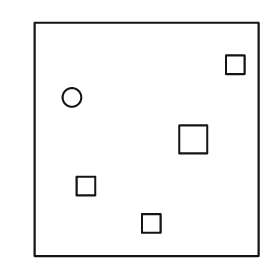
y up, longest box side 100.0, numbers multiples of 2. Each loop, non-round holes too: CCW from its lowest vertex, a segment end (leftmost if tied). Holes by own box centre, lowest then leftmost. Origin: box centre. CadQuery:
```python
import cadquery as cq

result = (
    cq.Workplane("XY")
    .moveTo(-48.0, -50.0)
    .lineTo(48.0, -50.0)
    .lineTo(48.0, 50.0)
    .lineTo(-48.0, 50.0)
    .close()
    .moveTo(-2.0, -40.0)
    .lineTo(6.0, -40.0)
    .lineTo(6.0, -32.0)
    .lineTo(-2.0, -32.0)
    .close()
    .moveTo(-30.0, -24.0)
    .lineTo(-22.0, -24.0)
    .lineTo(-22.0, -16.0)
    .lineTo(-30.0, -16.0)
    .close()
    .moveTo(14.0, -6.0)
    .lineTo(26.0, -6.0)
    .lineTo(26.0, 6.0)
    .lineTo(14.0, 6.0)
    .close()
    .moveTo(-32.0, 18.0)
    .circle(4.0)
    .moveTo(34.0, 28.0)
    .lineTo(42.0, 28.0)
    .lineTo(42.0, 36.0)
    .lineTo(34.0, 36.0)
    .close()
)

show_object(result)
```